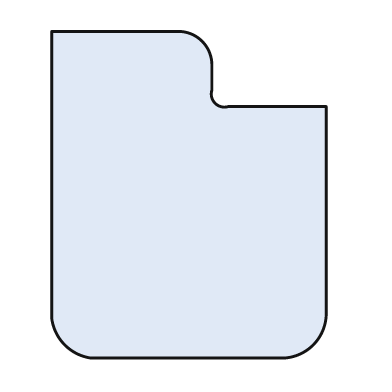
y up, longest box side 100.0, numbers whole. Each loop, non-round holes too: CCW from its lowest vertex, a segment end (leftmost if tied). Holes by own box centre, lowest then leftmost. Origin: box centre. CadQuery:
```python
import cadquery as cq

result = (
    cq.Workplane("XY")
    .moveTo(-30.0, -50.0)
    .lineTo(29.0, -50.0)
    .threePointArc((38.0, -46.0), (42.0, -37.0))
    .lineTo(42.0, 27.0)
    .lineTo(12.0, 27.0)
    .threePointArc((8.0, 28.0), (7.0, 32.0))
    .lineTo(7.0, 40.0)
    .threePointArc((4.0, 47.0), (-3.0, 50.0))
    .lineTo(-42.0, 50.0)
    .lineTo(-42.0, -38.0)
    .threePointArc((-38.0, -46.0), (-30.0, -50.0))
    .close()
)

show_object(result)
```